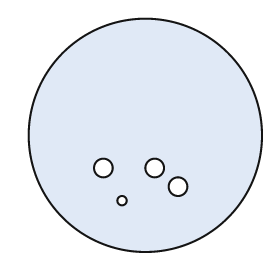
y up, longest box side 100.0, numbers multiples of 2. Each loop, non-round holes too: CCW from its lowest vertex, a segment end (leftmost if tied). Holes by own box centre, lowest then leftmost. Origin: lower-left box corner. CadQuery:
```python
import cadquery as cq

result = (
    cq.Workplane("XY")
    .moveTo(50.0, 50.0)
    .circle(50.0)
    .moveTo(40.0, 22.0)
    .circle(2.0)
    .moveTo(64.0, 28.0)
    .circle(4.0)
    .moveTo(32.0, 36.0)
    .circle(4.0)
    .moveTo(54.0, 36.0)
    .circle(4.0)
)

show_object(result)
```